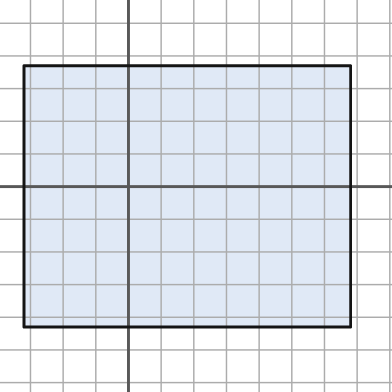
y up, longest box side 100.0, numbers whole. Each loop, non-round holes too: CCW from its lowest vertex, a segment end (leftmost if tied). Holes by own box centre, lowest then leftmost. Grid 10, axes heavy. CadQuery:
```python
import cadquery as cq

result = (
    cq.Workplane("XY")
    .moveTo(-32.0, -43.0)
    .lineTo(68.0, -43.0)
    .lineTo(68.0, 37.0)
    .lineTo(-32.0, 37.0)
    .close()
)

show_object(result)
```